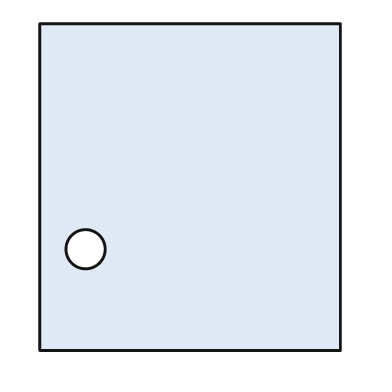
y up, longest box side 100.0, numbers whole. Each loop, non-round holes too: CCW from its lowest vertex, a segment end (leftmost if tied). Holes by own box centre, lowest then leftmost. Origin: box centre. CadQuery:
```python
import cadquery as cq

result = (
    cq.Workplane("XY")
    .moveTo(-46.0, -50.0)
    .lineTo(46.0, -50.0)
    .lineTo(46.0, 50.0)
    .lineTo(-46.0, 50.0)
    .close()
    .moveTo(-32.0, -19.0)
    .circle(6.0)
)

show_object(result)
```